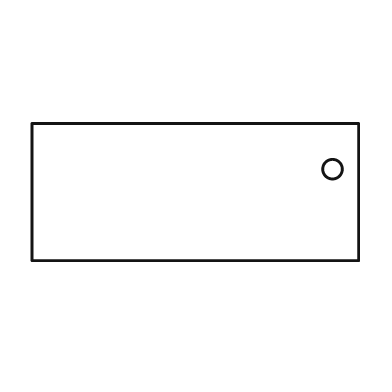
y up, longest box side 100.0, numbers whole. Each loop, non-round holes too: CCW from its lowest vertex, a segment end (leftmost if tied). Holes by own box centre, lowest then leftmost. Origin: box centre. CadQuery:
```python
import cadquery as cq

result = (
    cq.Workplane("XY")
    .moveTo(-50.0, -21.0)
    .lineTo(50.0, -21.0)
    .lineTo(50.0, 21.0)
    .lineTo(-50.0, 21.0)
    .close()
    .moveTo(42.0, 7.0)
    .circle(3.0)
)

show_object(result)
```